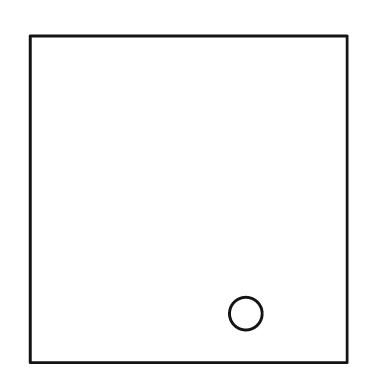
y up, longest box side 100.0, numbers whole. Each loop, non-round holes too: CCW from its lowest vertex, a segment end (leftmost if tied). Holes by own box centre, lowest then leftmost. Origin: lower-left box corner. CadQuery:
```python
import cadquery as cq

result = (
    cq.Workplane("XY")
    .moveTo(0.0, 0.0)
    .lineTo(97.0, 0.0)
    .lineTo(97.0, 100.0)
    .lineTo(0.0, 100.0)
    .close()
    .moveTo(66.0, 15.0)
    .circle(5.0)
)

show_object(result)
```